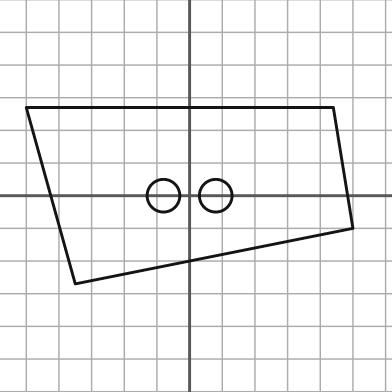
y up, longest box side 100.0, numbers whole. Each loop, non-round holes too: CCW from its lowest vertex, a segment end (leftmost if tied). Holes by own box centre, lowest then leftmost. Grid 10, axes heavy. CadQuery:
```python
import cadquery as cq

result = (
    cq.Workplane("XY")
    .moveTo(-35.0, -27.0)
    .lineTo(50.0, -10.0)
    .lineTo(44.0, 27.0)
    .lineTo(-50.0, 27.0)
    .close()
    .moveTo(-8.0, 0.0)
    .circle(5.0)
    .moveTo(8.0, 0.0)
    .circle(5.0)
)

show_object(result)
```